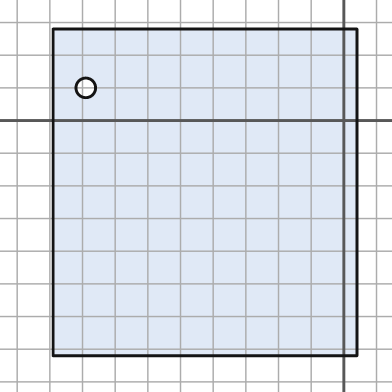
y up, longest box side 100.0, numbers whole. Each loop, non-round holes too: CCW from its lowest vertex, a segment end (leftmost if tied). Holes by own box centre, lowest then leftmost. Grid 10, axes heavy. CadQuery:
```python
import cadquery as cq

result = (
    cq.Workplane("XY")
    .moveTo(-89.0, -72.0)
    .lineTo(4.0, -72.0)
    .lineTo(4.0, 28.0)
    .lineTo(-89.0, 28.0)
    .close()
    .moveTo(-79.0, 10.0)
    .circle(3.0)
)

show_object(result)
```